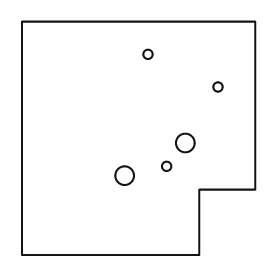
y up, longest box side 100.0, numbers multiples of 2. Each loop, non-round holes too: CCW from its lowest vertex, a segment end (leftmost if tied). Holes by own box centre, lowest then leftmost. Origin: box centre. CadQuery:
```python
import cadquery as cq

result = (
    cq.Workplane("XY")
    .moveTo(-50.0, -50.0)
    .lineTo(26.0, -50.0)
    .lineTo(26.0, -22.0)
    .lineTo(50.0, -22.0)
    .lineTo(50.0, 50.0)
    .lineTo(-50.0, 50.0)
    .close()
    .moveTo(-6.0, -16.0)
    .circle(4.0)
    .moveTo(12.0, -12.0)
    .circle(2.0)
    .moveTo(20.0, -2.0)
    .circle(4.0)
    .moveTo(34.0, 22.0)
    .circle(2.0)
    .moveTo(4.0, 36.0)
    .circle(2.0)
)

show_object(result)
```